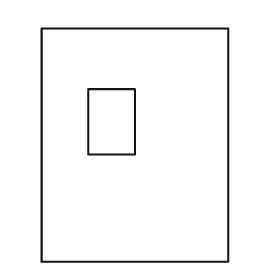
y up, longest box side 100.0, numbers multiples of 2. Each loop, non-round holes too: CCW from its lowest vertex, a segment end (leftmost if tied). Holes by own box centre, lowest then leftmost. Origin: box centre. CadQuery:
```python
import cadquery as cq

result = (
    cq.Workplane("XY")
    .moveTo(-40.0, -50.0)
    .lineTo(40.0, -50.0)
    .lineTo(40.0, 50.0)
    .lineTo(-40.0, 50.0)
    .close()
    .moveTo(-20.0, -4.0)
    .lineTo(0.0, -4.0)
    .lineTo(0.0, 24.0)
    .lineTo(-20.0, 24.0)
    .close()
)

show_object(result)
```